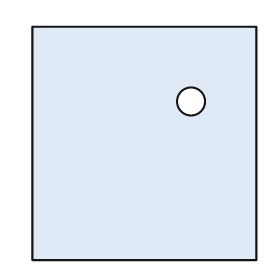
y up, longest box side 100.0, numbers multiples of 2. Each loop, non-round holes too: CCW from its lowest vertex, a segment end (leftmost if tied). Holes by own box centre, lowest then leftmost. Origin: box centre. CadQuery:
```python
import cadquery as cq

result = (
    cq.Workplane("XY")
    .moveTo(-48.0, -50.0)
    .lineTo(48.0, -50.0)
    .lineTo(48.0, 50.0)
    .lineTo(-48.0, 50.0)
    .close()
    .moveTo(20.0, 18.0)
    .circle(6.0)
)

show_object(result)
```